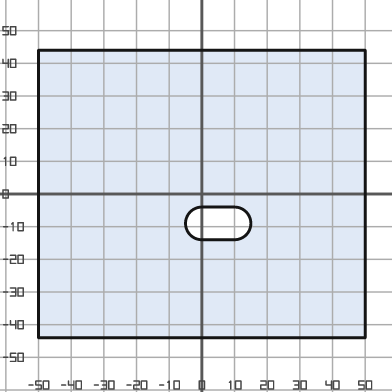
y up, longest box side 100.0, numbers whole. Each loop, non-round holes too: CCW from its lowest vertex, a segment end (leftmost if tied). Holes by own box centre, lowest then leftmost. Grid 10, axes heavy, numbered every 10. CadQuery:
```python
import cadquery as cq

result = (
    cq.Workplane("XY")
    .moveTo(-50.0, -44.0)
    .lineTo(50.0, -44.0)
    .lineTo(50.0, 44.0)
    .lineTo(-50.0, 44.0)
    .close()
    .moveTo(0.0, -14.0)
    .lineTo(10.0, -14.0)
    .threePointArc((15.0, -9.0), (10.0, -4.0))
    .lineTo(0.0, -4.0)
    .threePointArc((-5.0, -9.0), (0.0, -14.0))
    .close()
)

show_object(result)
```